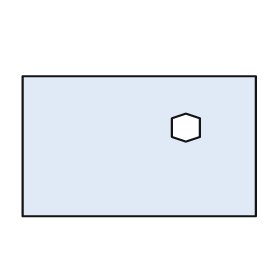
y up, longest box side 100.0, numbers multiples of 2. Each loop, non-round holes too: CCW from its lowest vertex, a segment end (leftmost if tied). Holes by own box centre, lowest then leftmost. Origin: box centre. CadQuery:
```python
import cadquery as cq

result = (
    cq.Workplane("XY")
    .moveTo(-50.0, -30.0)
    .lineTo(50.0, -30.0)
    .lineTo(50.0, 30.0)
    .lineTo(-50.0, 30.0)
    .close()
    .moveTo(20.0, 2.0)
    .lineTo(26.0, 4.0)
    .lineTo(26.0, 12.0)
    .lineTo(20.0, 14.0)
    .lineTo(14.0, 12.0)
    .lineTo(14.0, 4.0)
    .close()
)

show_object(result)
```